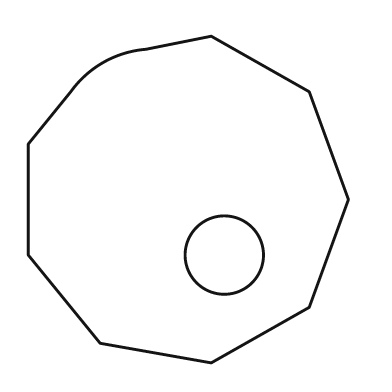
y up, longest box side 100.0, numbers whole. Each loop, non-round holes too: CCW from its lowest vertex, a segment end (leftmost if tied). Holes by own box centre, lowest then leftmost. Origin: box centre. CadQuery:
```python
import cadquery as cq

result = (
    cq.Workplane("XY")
    .moveTo(7.0, -50.0)
    .lineTo(37.0, -33.0)
    .lineTo(49.0, 0.0)
    .lineTo(37.0, 33.0)
    .lineTo(7.0, 50.0)
    .lineTo(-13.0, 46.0)
    .threePointArc((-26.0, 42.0), (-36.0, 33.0))
    .lineTo(-49.0, 17.0)
    .lineTo(-49.0, -17.0)
    .lineTo(-27.0, -44.0)
    .close()
    .moveTo(11.0, -17.0)
    .circle(12.0)
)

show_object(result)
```